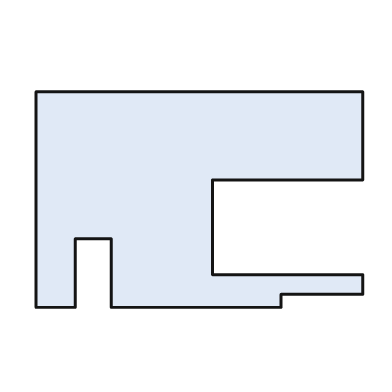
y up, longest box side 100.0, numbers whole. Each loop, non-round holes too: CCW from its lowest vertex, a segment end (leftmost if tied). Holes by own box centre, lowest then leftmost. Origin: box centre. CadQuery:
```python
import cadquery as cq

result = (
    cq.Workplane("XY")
    .moveTo(-50.0, -33.0)
    .lineTo(-38.0, -33.0)
    .lineTo(-38.0, -12.0)
    .lineTo(-27.0, -12.0)
    .lineTo(-27.0, -33.0)
    .lineTo(25.0, -33.0)
    .lineTo(25.0, -29.0)
    .lineTo(50.0, -29.0)
    .lineTo(50.0, -23.0)
    .lineTo(4.0, -23.0)
    .lineTo(4.0, 6.0)
    .lineTo(50.0, 6.0)
    .lineTo(50.0, 33.0)
    .lineTo(-50.0, 33.0)
    .close()
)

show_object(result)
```